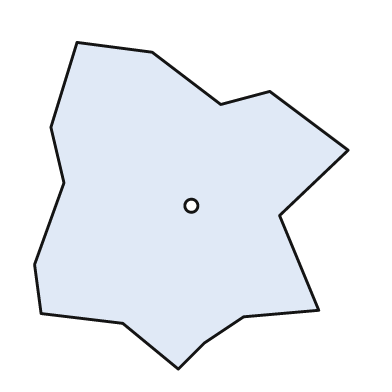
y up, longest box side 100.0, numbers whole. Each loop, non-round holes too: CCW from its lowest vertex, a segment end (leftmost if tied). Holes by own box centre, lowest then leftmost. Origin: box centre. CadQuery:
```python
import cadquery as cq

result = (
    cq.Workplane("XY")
    .moveTo(-4.0, -50.0)
    .lineTo(4.0, -42.0)
    .lineTo(16.0, -34.0)
    .lineTo(39.0, -32.0)
    .lineTo(27.0, -3.0)
    .lineTo(48.0, 17.0)
    .lineTo(24.0, 35.0)
    .lineTo(9.0, 31.0)
    .lineTo(-12.0, 47.0)
    .lineTo(-35.0, 50.0)
    .lineTo(-43.0, 24.0)
    .lineTo(-39.0, 7.0)
    .lineTo(-48.0, -18.0)
    .lineTo(-46.0, -33.0)
    .lineTo(-21.0, -36.0)
    .close()
    .moveTo(0.0, 0.0)
    .circle(2.0)
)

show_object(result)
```